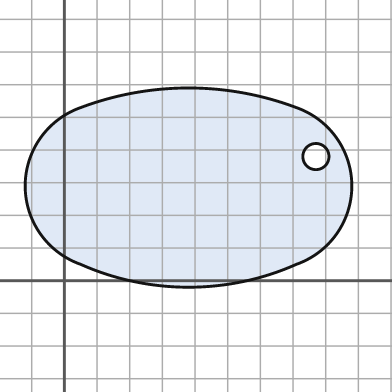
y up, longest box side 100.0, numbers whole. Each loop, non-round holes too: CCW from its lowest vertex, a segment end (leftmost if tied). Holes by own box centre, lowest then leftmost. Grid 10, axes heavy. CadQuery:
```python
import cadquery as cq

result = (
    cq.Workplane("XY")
    .moveTo(5.0, 5.0)
    .threePointArc((38.0, -2.0), (71.0, 5.0))
    .threePointArc((88.0, 29.0), (71.0, 53.0))
    .threePointArc((38.0, 59.0), (5.0, 53.0))
    .threePointArc((-12.0, 29.0), (5.0, 5.0))
    .close()
    .moveTo(77.0, 38.0)
    .circle(4.0)
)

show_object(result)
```